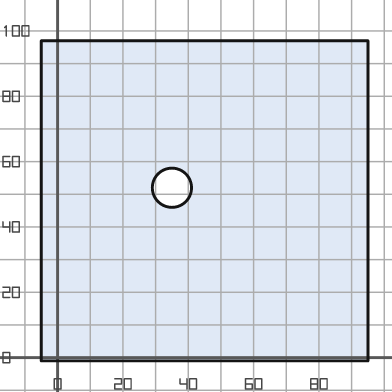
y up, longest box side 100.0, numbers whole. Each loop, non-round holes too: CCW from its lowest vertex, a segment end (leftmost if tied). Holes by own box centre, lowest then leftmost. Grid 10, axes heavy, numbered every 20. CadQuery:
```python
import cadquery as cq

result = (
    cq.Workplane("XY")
    .moveTo(-5.0, -1.0)
    .lineTo(95.0, -1.0)
    .lineTo(95.0, 97.0)
    .lineTo(-5.0, 97.0)
    .close()
    .moveTo(35.0, 52.0)
    .circle(6.0)
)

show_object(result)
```